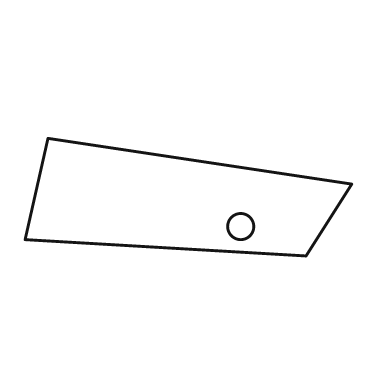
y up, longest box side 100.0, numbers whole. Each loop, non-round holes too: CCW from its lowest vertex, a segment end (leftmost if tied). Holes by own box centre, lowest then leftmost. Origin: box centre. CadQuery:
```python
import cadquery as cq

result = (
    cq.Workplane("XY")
    .moveTo(36.0, -18.0)
    .lineTo(50.0, 4.0)
    .lineTo(-43.0, 18.0)
    .lineTo(-50.0, -13.0)
    .close()
    .moveTo(16.0, -9.0)
    .circle(4.0)
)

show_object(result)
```